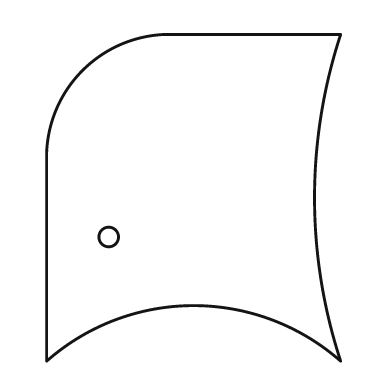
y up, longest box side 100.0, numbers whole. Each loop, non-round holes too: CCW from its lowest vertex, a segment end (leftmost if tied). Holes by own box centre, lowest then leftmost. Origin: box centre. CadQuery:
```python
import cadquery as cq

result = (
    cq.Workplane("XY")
    .moveTo(-45.0, -50.0)
    .threePointArc((0.0, -33.0), (45.0, -50.0))
    .threePointArc((37.0, 0.0), (45.0, 50.0))
    .lineTo(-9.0, 50.0)
    .threePointArc((-34.0, 39.0), (-45.0, 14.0))
    .close()
    .moveTo(-26.0, -12.0)
    .circle(3.0)
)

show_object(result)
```